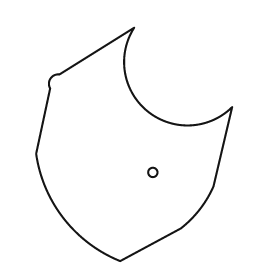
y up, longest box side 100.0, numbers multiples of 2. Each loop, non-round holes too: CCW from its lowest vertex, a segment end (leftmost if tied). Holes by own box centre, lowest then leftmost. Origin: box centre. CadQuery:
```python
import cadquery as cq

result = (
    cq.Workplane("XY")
    .moveTo(-6.0, -50.0)
    .lineTo(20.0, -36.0)
    .threePointArc((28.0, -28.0), (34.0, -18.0))
    .lineTo(42.0, 16.0)
    .threePointArc((6.0, 14.0), (0.0, 50.0))
    .lineTo(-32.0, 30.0)
    .threePointArc((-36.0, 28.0), (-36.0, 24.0))
    .lineTo(-42.0, -4.0)
    .threePointArc((-30.0, -32.0), (-6.0, -50.0))
    .close()
    .moveTo(8.0, -12.0)
    .circle(2.0)
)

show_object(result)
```